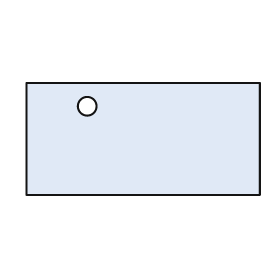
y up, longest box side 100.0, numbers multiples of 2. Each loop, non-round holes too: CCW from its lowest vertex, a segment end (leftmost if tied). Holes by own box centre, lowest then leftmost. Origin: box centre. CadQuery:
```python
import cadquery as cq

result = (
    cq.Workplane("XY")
    .moveTo(-50.0, -24.0)
    .lineTo(50.0, -24.0)
    .lineTo(50.0, 24.0)
    .lineTo(-50.0, 24.0)
    .close()
    .moveTo(-24.0, 14.0)
    .circle(4.0)
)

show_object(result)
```